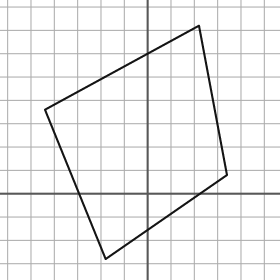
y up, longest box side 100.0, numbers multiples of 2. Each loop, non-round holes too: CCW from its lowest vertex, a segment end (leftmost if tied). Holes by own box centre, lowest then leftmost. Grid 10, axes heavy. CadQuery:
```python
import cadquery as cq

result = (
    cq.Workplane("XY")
    .moveTo(-18.0, -28.0)
    .lineTo(34.0, 8.0)
    .lineTo(22.0, 72.0)
    .lineTo(-44.0, 36.0)
    .close()
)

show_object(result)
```